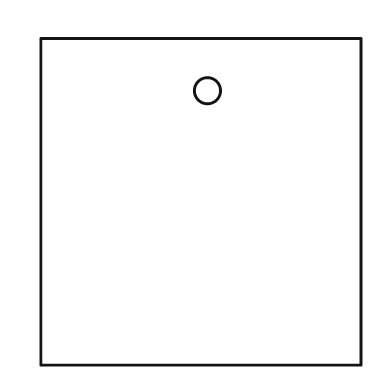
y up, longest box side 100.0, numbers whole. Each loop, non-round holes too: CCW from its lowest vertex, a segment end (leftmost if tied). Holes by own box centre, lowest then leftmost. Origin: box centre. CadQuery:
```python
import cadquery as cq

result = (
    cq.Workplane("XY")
    .moveTo(-49.0, -50.0)
    .lineTo(49.0, -50.0)
    .lineTo(49.0, 50.0)
    .lineTo(-49.0, 50.0)
    .close()
    .moveTo(2.0, 34.0)
    .circle(4.0)
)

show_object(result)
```